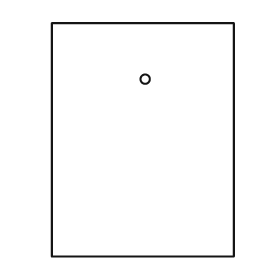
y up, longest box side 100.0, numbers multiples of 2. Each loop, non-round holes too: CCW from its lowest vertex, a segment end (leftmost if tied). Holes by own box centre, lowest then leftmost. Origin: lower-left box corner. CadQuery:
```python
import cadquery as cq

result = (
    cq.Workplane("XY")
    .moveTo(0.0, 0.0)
    .lineTo(78.0, 0.0)
    .lineTo(78.0, 100.0)
    .lineTo(0.0, 100.0)
    .close()
    .moveTo(40.0, 76.0)
    .circle(2.0)
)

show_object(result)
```